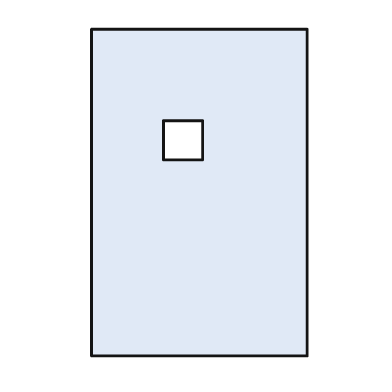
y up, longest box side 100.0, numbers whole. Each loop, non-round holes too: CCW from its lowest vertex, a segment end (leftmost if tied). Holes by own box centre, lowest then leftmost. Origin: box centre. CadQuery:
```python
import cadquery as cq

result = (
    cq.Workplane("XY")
    .moveTo(-33.0, -50.0)
    .lineTo(33.0, -50.0)
    .lineTo(33.0, 50.0)
    .lineTo(-33.0, 50.0)
    .close()
    .moveTo(-11.0, 10.0)
    .lineTo(1.0, 10.0)
    .lineTo(1.0, 22.0)
    .lineTo(-11.0, 22.0)
    .close()
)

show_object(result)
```